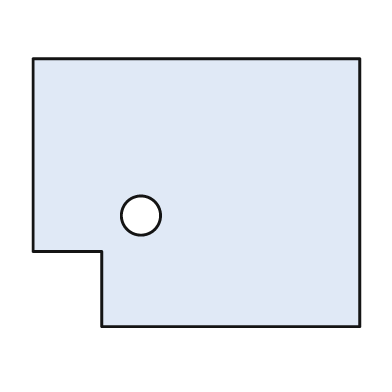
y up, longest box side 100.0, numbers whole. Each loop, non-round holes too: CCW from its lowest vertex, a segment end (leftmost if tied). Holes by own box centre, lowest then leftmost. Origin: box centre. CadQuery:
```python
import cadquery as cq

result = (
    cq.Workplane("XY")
    .moveTo(-29.0, -41.0)
    .lineTo(50.0, -41.0)
    .lineTo(50.0, 41.0)
    .lineTo(-50.0, 41.0)
    .lineTo(-50.0, -18.0)
    .lineTo(-29.0, -18.0)
    .close()
    .moveTo(-17.0, -7.0)
    .circle(6.0)
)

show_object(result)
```